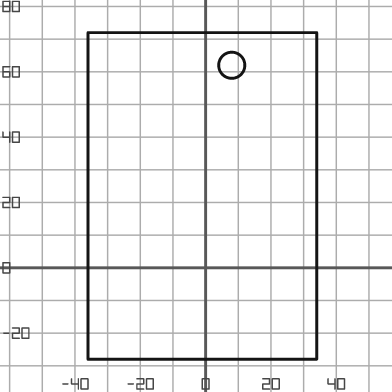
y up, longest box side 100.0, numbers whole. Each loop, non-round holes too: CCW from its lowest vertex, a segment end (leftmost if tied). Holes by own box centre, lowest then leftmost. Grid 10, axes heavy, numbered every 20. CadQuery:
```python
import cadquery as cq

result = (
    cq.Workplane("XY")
    .moveTo(-36.0, -28.0)
    .lineTo(34.0, -28.0)
    .lineTo(34.0, 72.0)
    .lineTo(-36.0, 72.0)
    .close()
    .moveTo(8.0, 62.0)
    .circle(4.0)
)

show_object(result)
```